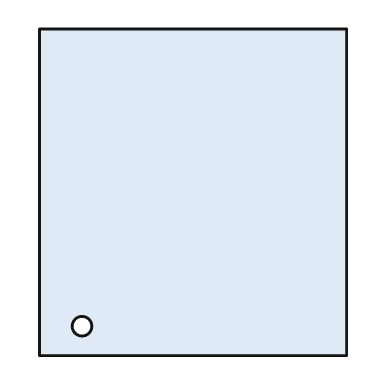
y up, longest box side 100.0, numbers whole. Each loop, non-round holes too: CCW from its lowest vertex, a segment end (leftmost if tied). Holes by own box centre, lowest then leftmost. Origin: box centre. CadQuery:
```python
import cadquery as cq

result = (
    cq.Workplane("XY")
    .moveTo(-47.0, -50.0)
    .lineTo(47.0, -50.0)
    .lineTo(47.0, 50.0)
    .lineTo(-47.0, 50.0)
    .close()
    .moveTo(-34.0, -41.0)
    .circle(3.0)
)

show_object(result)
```